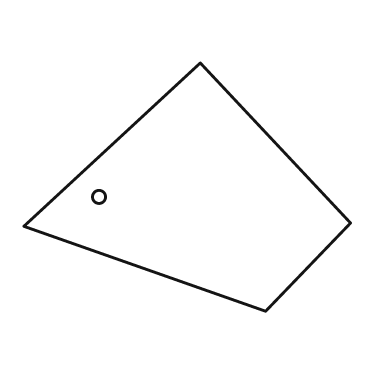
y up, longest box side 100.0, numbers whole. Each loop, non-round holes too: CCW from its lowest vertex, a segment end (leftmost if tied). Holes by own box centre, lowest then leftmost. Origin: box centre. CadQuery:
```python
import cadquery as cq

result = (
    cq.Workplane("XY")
    .moveTo(24.0, -38.0)
    .lineTo(50.0, -11.0)
    .lineTo(4.0, 38.0)
    .lineTo(-50.0, -12.0)
    .close()
    .moveTo(-27.0, -3.0)
    .circle(2.0)
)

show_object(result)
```